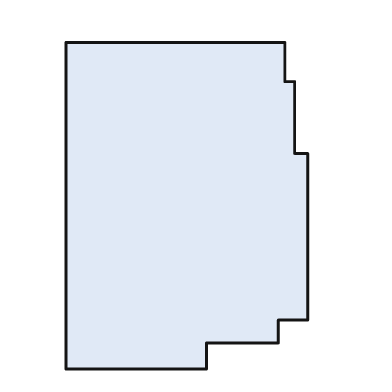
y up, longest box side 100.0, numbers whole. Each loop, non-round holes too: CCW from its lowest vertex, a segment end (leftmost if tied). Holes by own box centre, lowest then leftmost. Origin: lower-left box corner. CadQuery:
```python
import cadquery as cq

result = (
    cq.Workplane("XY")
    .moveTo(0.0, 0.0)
    .lineTo(43.0, 0.0)
    .lineTo(43.0, 8.0)
    .lineTo(65.0, 8.0)
    .lineTo(65.0, 15.0)
    .lineTo(74.0, 15.0)
    .lineTo(74.0, 66.0)
    .lineTo(70.0, 66.0)
    .lineTo(70.0, 88.0)
    .lineTo(67.0, 88.0)
    .lineTo(67.0, 100.0)
    .lineTo(0.0, 100.0)
    .close()
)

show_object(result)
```